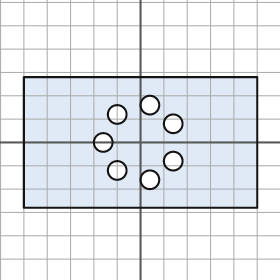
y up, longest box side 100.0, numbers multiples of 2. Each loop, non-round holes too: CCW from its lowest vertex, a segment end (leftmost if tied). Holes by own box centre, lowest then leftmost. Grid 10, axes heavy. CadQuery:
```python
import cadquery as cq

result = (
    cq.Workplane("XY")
    .moveTo(-50.0, -28.0)
    .lineTo(50.0, -28.0)
    .lineTo(50.0, 28.0)
    .lineTo(-50.0, 28.0)
    .close()
    .moveTo(4.0, -16.0)
    .circle(4.0)
    .moveTo(-10.0, -12.0)
    .circle(4.0)
    .moveTo(14.0, -8.0)
    .circle(4.0)
    .moveTo(-16.0, 0.0)
    .circle(4.0)
    .moveTo(14.0, 8.0)
    .circle(4.0)
    .moveTo(-10.0, 12.0)
    .circle(4.0)
    .moveTo(4.0, 16.0)
    .circle(4.0)
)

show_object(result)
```